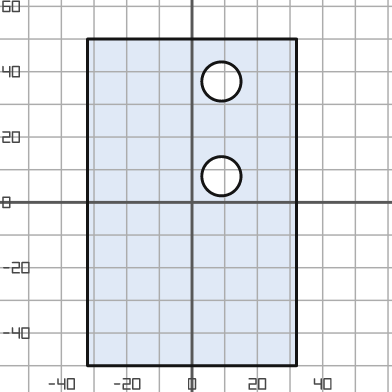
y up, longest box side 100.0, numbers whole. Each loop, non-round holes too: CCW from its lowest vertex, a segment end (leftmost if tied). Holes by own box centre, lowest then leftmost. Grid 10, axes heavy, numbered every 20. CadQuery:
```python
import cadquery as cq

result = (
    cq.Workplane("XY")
    .moveTo(-32.0, -50.0)
    .lineTo(32.0, -50.0)
    .lineTo(32.0, 50.0)
    .lineTo(-32.0, 50.0)
    .close()
    .moveTo(9.0, 8.0)
    .circle(6.0)
    .moveTo(9.0, 37.0)
    .circle(6.0)
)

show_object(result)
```